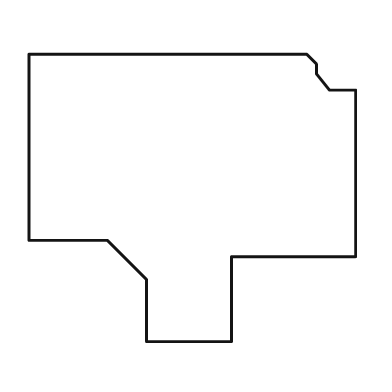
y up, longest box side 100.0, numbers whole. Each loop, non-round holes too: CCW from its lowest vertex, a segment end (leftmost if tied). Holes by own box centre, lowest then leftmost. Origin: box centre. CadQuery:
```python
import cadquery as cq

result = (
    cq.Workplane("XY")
    .moveTo(-14.0, -44.0)
    .lineTo(12.0, -44.0)
    .lineTo(12.0, -18.0)
    .lineTo(50.0, -18.0)
    .lineTo(50.0, 33.0)
    .lineTo(42.0, 33.0)
    .lineTo(38.0, 38.0)
    .lineTo(38.0, 41.0)
    .lineTo(35.0, 44.0)
    .lineTo(-50.0, 44.0)
    .lineTo(-50.0, -13.0)
    .lineTo(-26.0, -13.0)
    .lineTo(-14.0, -25.0)
    .close()
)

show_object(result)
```